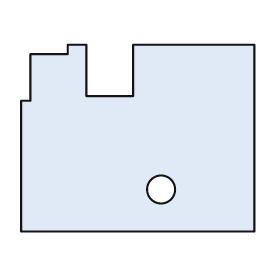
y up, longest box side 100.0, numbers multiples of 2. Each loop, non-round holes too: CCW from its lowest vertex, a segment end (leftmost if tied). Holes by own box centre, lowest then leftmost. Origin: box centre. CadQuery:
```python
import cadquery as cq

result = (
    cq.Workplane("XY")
    .moveTo(-50.0, -40.0)
    .lineTo(50.0, -40.0)
    .lineTo(50.0, 40.0)
    .lineTo(-2.0, 40.0)
    .lineTo(-2.0, 18.0)
    .lineTo(-22.0, 18.0)
    .lineTo(-22.0, 40.0)
    .lineTo(-30.0, 40.0)
    .lineTo(-30.0, 36.0)
    .lineTo(-46.0, 36.0)
    .lineTo(-46.0, 16.0)
    .lineTo(-50.0, 16.0)
    .close()
    .moveTo(10.0, -22.0)
    .circle(6.0)
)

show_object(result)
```